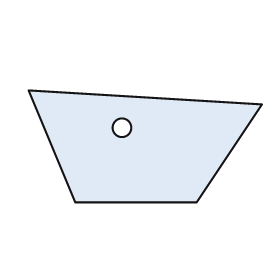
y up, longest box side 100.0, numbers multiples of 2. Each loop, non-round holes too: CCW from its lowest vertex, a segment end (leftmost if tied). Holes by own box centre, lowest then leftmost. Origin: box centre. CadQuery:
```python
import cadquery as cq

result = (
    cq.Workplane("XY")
    .moveTo(-30.0, -24.0)
    .lineTo(22.0, -24.0)
    .lineTo(50.0, 18.0)
    .lineTo(-50.0, 24.0)
    .close()
    .moveTo(-10.0, 8.0)
    .circle(4.0)
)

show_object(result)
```